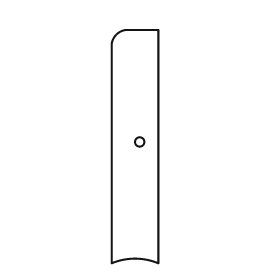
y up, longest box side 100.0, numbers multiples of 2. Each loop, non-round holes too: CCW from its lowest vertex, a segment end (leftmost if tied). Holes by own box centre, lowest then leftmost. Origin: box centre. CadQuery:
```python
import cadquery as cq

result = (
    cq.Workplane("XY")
    .moveTo(-10.0, -50.0)
    .threePointArc((0.0, -48.0), (10.0, -50.0))
    .lineTo(10.0, 50.0)
    .lineTo(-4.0, 50.0)
    .threePointArc((-8.0, 48.0), (-10.0, 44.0))
    .close()
    .moveTo(2.0, 2.0)
    .circle(2.0)
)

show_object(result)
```